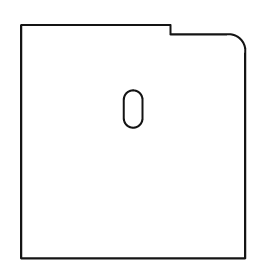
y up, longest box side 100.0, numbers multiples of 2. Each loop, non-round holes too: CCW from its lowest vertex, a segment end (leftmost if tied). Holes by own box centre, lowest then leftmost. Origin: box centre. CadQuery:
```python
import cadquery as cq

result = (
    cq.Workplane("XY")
    .moveTo(-48.0, -50.0)
    .lineTo(48.0, -50.0)
    .lineTo(48.0, 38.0)
    .threePointArc((46.0, 44.0), (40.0, 46.0))
    .lineTo(16.0, 46.0)
    .lineTo(16.0, 50.0)
    .lineTo(-48.0, 50.0)
    .close()
    .moveTo(-4.0, 10.0)
    .threePointArc((0.0, 6.0), (4.0, 10.0))
    .lineTo(4.0, 18.0)
    .threePointArc((0.0, 22.0), (-4.0, 18.0))
    .close()
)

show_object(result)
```